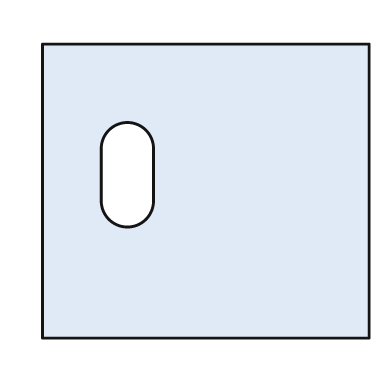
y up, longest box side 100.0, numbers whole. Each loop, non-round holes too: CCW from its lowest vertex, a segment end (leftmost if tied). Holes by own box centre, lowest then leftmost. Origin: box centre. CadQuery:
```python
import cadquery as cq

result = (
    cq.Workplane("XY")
    .moveTo(-50.0, -45.0)
    .lineTo(50.0, -45.0)
    .lineTo(50.0, 45.0)
    .lineTo(-50.0, 45.0)
    .close()
    .moveTo(-32.0, -3.0)
    .threePointArc((-24.0, -11.0), (-16.0, -3.0))
    .lineTo(-16.0, 13.0)
    .threePointArc((-24.0, 21.0), (-32.0, 13.0))
    .close()
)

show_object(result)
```